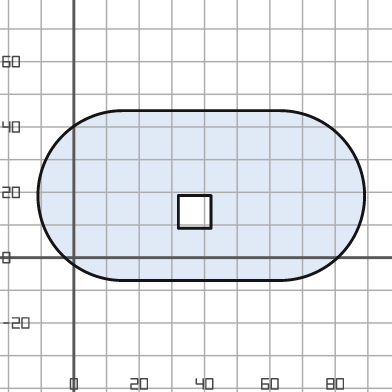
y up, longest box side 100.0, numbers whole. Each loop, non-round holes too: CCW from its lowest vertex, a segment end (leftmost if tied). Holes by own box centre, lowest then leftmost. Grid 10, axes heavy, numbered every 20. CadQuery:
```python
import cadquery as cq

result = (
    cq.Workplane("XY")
    .moveTo(15.0, -7.0)
    .lineTo(63.0, -7.0)
    .threePointArc((89.0, 19.0), (63.0, 45.0))
    .lineTo(15.0, 45.0)
    .threePointArc((-11.0, 19.0), (15.0, -7.0))
    .close()
    .moveTo(32.0, 9.0)
    .lineTo(42.0, 9.0)
    .lineTo(42.0, 19.0)
    .lineTo(32.0, 19.0)
    .close()
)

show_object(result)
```